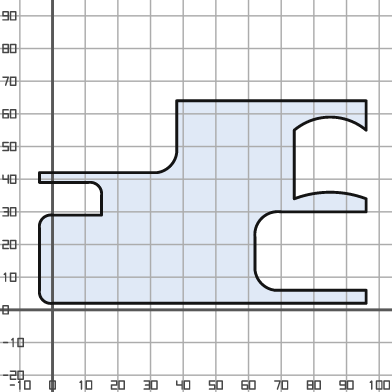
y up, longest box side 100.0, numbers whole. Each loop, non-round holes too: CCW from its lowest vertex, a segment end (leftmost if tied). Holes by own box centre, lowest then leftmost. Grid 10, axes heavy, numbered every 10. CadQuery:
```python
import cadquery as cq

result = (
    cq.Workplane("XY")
    .moveTo(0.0, 2.0)
    .lineTo(96.0, 2.0)
    .lineTo(96.0, 6.0)
    .lineTo(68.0, 6.0)
    .threePointArc((64.0, 8.0), (62.0, 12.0))
    .lineTo(62.0, 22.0)
    .threePointArc((64.0, 28.0), (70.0, 30.0))
    .lineTo(96.0, 30.0)
    .lineTo(96.0, 34.0)
    .threePointArc((85.0, 36.0), (74.0, 34.0))
    .lineTo(74.0, 55.0)
    .threePointArc((85.0, 59.0), (96.0, 55.0))
    .lineTo(96.0, 64.0)
    .lineTo(38.0, 64.0)
    .lineTo(38.0, 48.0)
    .threePointArc((36.0, 44.0), (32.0, 42.0))
    .lineTo(-4.0, 42.0)
    .lineTo(-4.0, 39.0)
    .lineTo(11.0, 39.0)
    .threePointArc((14.0, 38.0), (15.0, 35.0))
    .lineTo(15.0, 29.0)
    .lineTo(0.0, 29.0)
    .threePointArc((-3.0, 28.0), (-4.0, 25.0))
    .lineTo(-4.0, 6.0)
    .threePointArc((-3.0, 3.0), (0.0, 2.0))
    .close()
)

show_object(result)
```